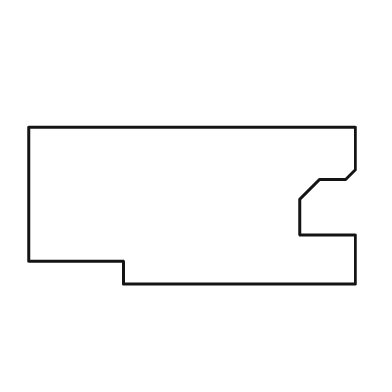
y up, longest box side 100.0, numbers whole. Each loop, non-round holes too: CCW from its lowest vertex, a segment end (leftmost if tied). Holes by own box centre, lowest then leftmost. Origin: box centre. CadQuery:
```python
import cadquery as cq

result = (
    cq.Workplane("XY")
    .moveTo(-21.0, -24.0)
    .lineTo(50.0, -24.0)
    .lineTo(50.0, -9.0)
    .lineTo(33.0, -9.0)
    .lineTo(33.0, 2.0)
    .lineTo(39.0, 8.0)
    .lineTo(47.0, 8.0)
    .lineTo(50.0, 11.0)
    .lineTo(50.0, 24.0)
    .lineTo(-50.0, 24.0)
    .lineTo(-50.0, -17.0)
    .lineTo(-21.0, -17.0)
    .close()
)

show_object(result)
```